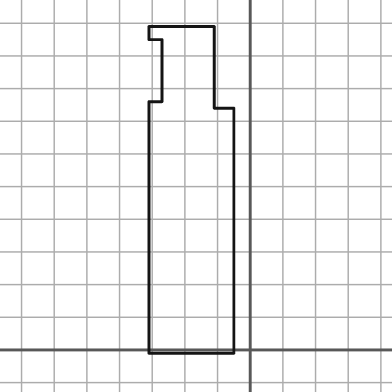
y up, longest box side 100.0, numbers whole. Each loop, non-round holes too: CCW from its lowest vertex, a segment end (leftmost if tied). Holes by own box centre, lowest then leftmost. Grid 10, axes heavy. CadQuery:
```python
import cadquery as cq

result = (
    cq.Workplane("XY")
    .moveTo(-31.0, -1.0)
    .lineTo(-5.0, -1.0)
    .lineTo(-5.0, 74.0)
    .lineTo(-11.0, 74.0)
    .lineTo(-11.0, 99.0)
    .lineTo(-31.0, 99.0)
    .lineTo(-31.0, 95.0)
    .lineTo(-27.0, 95.0)
    .lineTo(-27.0, 76.0)
    .lineTo(-31.0, 76.0)
    .close()
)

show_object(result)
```